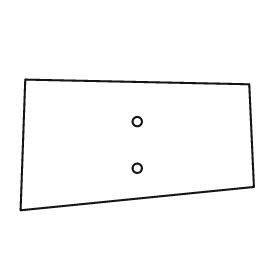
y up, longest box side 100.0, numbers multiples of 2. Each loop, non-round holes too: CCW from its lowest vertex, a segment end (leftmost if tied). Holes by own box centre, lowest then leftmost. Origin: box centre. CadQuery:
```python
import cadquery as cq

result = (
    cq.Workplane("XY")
    .moveTo(-50.0, -28.0)
    .lineTo(50.0, -18.0)
    .lineTo(48.0, 26.0)
    .lineTo(-48.0, 28.0)
    .close()
    .moveTo(0.0, -10.0)
    .circle(2.0)
    .moveTo(0.0, 10.0)
    .circle(2.0)
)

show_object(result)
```